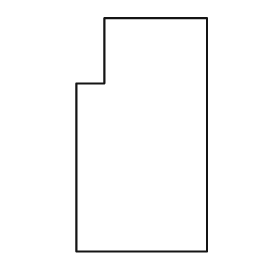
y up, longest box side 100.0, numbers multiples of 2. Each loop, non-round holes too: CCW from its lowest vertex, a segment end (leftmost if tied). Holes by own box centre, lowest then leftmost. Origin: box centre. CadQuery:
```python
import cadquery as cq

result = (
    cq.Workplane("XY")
    .moveTo(-28.0, -50.0)
    .lineTo(28.0, -50.0)
    .lineTo(28.0, 50.0)
    .lineTo(-16.0, 50.0)
    .lineTo(-16.0, 22.0)
    .lineTo(-28.0, 22.0)
    .close()
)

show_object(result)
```